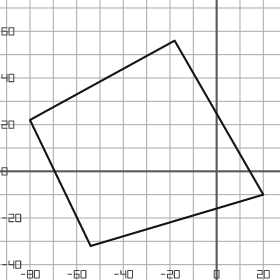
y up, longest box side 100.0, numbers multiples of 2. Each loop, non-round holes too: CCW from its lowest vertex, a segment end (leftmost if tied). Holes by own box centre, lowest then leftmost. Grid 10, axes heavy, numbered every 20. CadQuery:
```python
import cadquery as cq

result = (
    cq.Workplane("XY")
    .moveTo(-54.0, -32.0)
    .lineTo(20.0, -10.0)
    .lineTo(-18.0, 56.0)
    .lineTo(-80.0, 22.0)
    .close()
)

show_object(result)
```